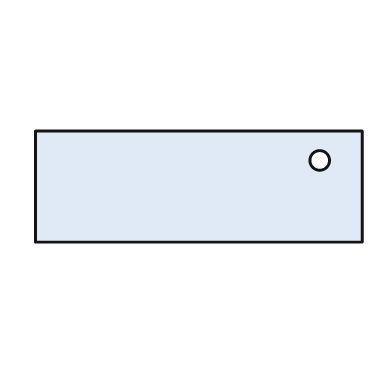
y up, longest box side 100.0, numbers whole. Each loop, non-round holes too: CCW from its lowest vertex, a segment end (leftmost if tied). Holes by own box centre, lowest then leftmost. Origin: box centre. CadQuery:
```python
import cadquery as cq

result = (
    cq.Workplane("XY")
    .moveTo(-50.0, -17.0)
    .lineTo(50.0, -17.0)
    .lineTo(50.0, 17.0)
    .lineTo(-50.0, 17.0)
    .close()
    .moveTo(37.0, 8.0)
    .circle(3.0)
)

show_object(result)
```